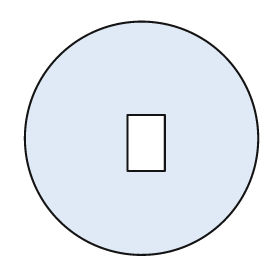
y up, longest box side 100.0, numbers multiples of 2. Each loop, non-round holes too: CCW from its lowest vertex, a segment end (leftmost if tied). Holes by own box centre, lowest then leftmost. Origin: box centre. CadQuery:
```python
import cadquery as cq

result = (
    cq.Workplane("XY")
    .moveTo(0.0, 0.0)
    .circle(50.0)
    .moveTo(-6.0, -14.0)
    .lineTo(10.0, -14.0)
    .lineTo(10.0, 10.0)
    .lineTo(-6.0, 10.0)
    .close()
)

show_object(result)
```